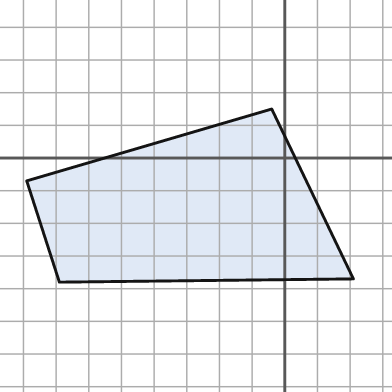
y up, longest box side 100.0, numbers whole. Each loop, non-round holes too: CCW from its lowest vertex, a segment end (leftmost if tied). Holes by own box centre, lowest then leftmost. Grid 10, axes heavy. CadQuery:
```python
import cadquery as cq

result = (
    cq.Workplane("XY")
    .moveTo(-69.0, -38.0)
    .lineTo(21.0, -37.0)
    .lineTo(-4.0, 15.0)
    .lineTo(-79.0, -7.0)
    .close()
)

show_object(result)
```